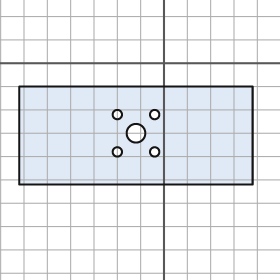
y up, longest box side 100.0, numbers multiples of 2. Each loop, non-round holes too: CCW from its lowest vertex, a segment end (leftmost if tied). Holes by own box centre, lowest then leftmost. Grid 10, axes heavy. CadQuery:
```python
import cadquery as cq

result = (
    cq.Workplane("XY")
    .moveTo(-62.0, -52.0)
    .lineTo(38.0, -52.0)
    .lineTo(38.0, -10.0)
    .lineTo(-62.0, -10.0)
    .close()
    .moveTo(-20.0, -38.0)
    .circle(2.0)
    .moveTo(-4.0, -38.0)
    .circle(2.0)
    .moveTo(-12.0, -30.0)
    .circle(4.0)
    .moveTo(-20.0, -22.0)
    .circle(2.0)
    .moveTo(-4.0, -22.0)
    .circle(2.0)
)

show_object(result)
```